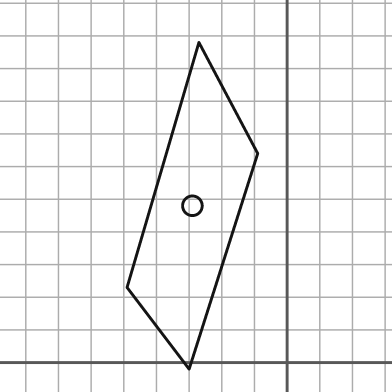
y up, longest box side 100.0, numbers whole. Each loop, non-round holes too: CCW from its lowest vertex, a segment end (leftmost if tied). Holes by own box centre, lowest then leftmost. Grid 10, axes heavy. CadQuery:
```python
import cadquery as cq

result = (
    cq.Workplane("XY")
    .moveTo(-30.0, -2.0)
    .lineTo(-9.0, 64.0)
    .lineTo(-27.0, 98.0)
    .lineTo(-49.0, 23.0)
    .close()
    .moveTo(-29.0, 48.0)
    .circle(3.0)
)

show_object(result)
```